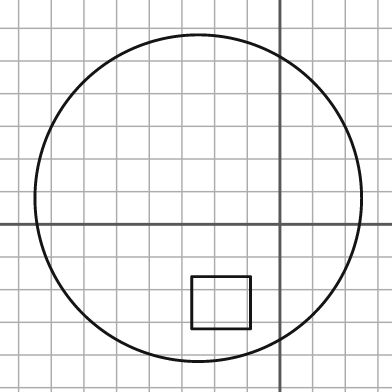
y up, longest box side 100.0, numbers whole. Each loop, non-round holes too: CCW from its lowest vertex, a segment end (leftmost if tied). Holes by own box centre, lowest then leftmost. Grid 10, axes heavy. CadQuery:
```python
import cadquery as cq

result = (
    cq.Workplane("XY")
    .moveTo(-25.0, 8.0)
    .circle(50.0)
    .moveTo(-27.0, -32.0)
    .lineTo(-9.0, -32.0)
    .lineTo(-9.0, -16.0)
    .lineTo(-27.0, -16.0)
    .close()
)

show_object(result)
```